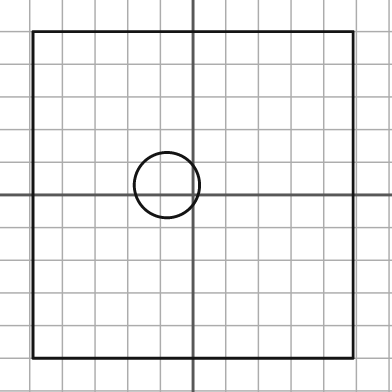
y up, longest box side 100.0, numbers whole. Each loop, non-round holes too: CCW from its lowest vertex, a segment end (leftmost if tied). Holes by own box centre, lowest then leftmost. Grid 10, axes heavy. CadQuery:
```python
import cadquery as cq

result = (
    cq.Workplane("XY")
    .moveTo(-49.0, -50.0)
    .lineTo(49.0, -50.0)
    .lineTo(49.0, 50.0)
    .lineTo(-49.0, 50.0)
    .close()
    .moveTo(-8.0, 3.0)
    .circle(10.0)
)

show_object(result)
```